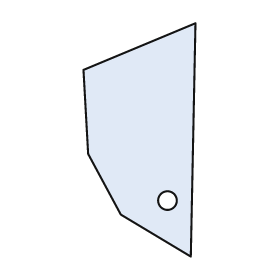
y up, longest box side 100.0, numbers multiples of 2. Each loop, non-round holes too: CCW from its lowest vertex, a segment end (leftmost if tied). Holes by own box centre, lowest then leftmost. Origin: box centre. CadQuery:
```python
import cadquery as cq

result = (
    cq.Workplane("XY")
    .moveTo(22.0, -50.0)
    .lineTo(24.0, 50.0)
    .lineTo(-24.0, 30.0)
    .lineTo(-22.0, -6.0)
    .lineTo(-8.0, -32.0)
    .close()
    .moveTo(12.0, -26.0)
    .circle(4.0)
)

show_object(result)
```